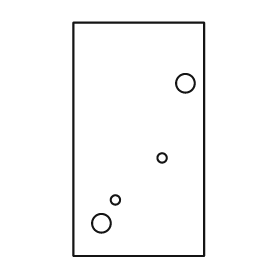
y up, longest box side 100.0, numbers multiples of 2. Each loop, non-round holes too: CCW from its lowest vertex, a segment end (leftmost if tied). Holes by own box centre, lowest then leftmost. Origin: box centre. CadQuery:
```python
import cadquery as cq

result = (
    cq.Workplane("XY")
    .moveTo(-28.0, -50.0)
    .lineTo(28.0, -50.0)
    .lineTo(28.0, 50.0)
    .lineTo(-28.0, 50.0)
    .close()
    .moveTo(-16.0, -36.0)
    .circle(4.0)
    .moveTo(-10.0, -26.0)
    .circle(2.0)
    .moveTo(10.0, -8.0)
    .circle(2.0)
    .moveTo(20.0, 24.0)
    .circle(4.0)
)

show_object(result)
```